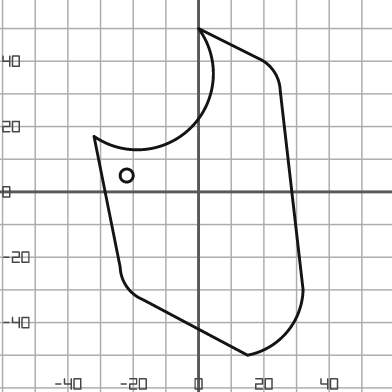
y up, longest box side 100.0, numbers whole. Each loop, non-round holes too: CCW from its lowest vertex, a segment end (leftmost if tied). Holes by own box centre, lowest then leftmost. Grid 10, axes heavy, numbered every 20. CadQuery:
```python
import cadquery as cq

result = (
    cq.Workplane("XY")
    .moveTo(15.0, -50.0)
    .threePointArc((27.0, -43.0), (32.0, -30.0))
    .lineTo(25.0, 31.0)
    .threePointArc((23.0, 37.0), (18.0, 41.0))
    .lineTo(0.0, 50.0)
    .threePointArc((-2.0, 20.0), (-32.0, 17.0))
    .lineTo(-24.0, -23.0)
    .threePointArc((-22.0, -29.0), (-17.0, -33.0))
    .close()
    .moveTo(-22.0, 5.0)
    .circle(2.0)
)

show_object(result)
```